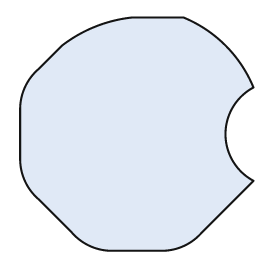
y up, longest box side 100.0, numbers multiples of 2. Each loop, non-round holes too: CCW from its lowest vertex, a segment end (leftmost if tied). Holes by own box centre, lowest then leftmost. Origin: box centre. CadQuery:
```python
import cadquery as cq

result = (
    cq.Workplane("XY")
    .moveTo(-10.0, -50.0)
    .lineTo(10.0, -50.0)
    .threePointArc((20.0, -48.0), (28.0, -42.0))
    .lineTo(50.0, -20.0)
    .threePointArc((38.0, 0.0), (50.0, 20.0))
    .threePointArc((38.0, 38.0), (20.0, 50.0))
    .lineTo(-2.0, 50.0)
    .threePointArc((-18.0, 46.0), (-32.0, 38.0))
    .lineTo(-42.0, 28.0)
    .threePointArc((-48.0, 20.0), (-50.0, 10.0))
    .lineTo(-50.0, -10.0)
    .threePointArc((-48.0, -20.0), (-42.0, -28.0))
    .lineTo(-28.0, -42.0)
    .threePointArc((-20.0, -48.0), (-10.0, -50.0))
    .close()
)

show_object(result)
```